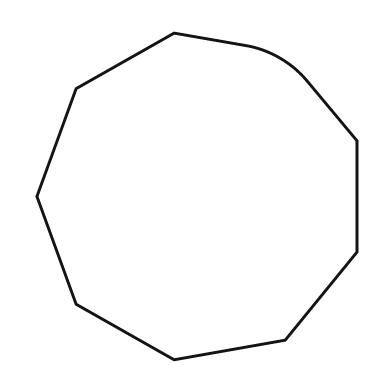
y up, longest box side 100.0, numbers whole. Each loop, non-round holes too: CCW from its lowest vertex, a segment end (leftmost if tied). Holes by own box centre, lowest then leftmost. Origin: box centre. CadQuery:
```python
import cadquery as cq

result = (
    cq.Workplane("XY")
    .moveTo(-7.0, -50.0)
    .lineTo(27.0, -44.0)
    .lineTo(49.0, -17.0)
    .lineTo(49.0, 17.0)
    .lineTo(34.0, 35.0)
    .threePointArc((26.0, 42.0), (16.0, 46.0))
    .lineTo(-7.0, 50.0)
    .lineTo(-37.0, 33.0)
    .lineTo(-49.0, 0.0)
    .lineTo(-37.0, -33.0)
    .close()
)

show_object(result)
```